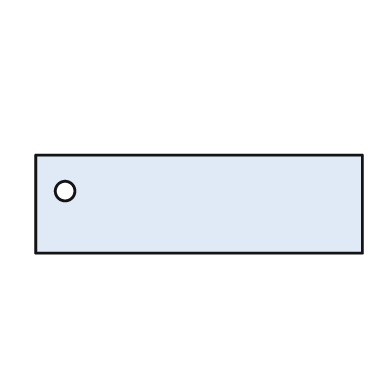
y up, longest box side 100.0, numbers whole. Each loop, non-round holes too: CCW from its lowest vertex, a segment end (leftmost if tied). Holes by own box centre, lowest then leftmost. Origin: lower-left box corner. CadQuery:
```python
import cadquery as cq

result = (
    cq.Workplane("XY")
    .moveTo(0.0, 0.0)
    .lineTo(100.0, 0.0)
    .lineTo(100.0, 30.0)
    .lineTo(0.0, 30.0)
    .close()
    .moveTo(9.0, 19.0)
    .circle(3.0)
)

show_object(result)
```